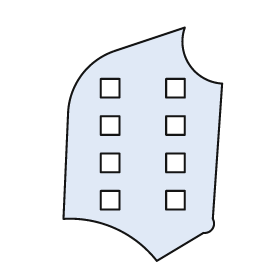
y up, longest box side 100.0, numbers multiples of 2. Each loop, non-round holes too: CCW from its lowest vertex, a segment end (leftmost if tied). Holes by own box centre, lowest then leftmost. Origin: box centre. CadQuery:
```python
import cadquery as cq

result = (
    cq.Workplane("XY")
    .moveTo(6.0, -50.0)
    .lineTo(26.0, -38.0)
    .threePointArc((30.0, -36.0), (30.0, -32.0))
    .lineTo(34.0, 26.0)
    .threePointArc((20.0, 34.0), (18.0, 50.0))
    .lineTo(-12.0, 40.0)
    .threePointArc((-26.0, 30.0), (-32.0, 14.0))
    .lineTo(-34.0, -32.0)
    .threePointArc((-12.0, -36.0), (6.0, -50.0))
    .close()
    .moveTo(-18.0, -28.0)
    .lineTo(-10.0, -28.0)
    .lineTo(-10.0, -20.0)
    .lineTo(-18.0, -20.0)
    .close()
    .moveTo(10.0, -28.0)
    .lineTo(18.0, -28.0)
    .lineTo(18.0, -20.0)
    .lineTo(10.0, -20.0)
    .close()
    .moveTo(-18.0, -12.0)
    .lineTo(-10.0, -12.0)
    .lineTo(-10.0, -4.0)
    .lineTo(-18.0, -4.0)
    .close()
    .moveTo(10.0, -12.0)
    .lineTo(18.0, -12.0)
    .lineTo(18.0, -4.0)
    .lineTo(10.0, -4.0)
    .close()
    .moveTo(-18.0, 4.0)
    .lineTo(-10.0, 4.0)
    .lineTo(-10.0, 12.0)
    .lineTo(-18.0, 12.0)
    .close()
    .moveTo(10.0, 4.0)
    .lineTo(18.0, 4.0)
    .lineTo(18.0, 12.0)
    .lineTo(10.0, 12.0)
    .close()
    .moveTo(-18.0, 20.0)
    .lineTo(-10.0, 20.0)
    .lineTo(-10.0, 28.0)
    .lineTo(-18.0, 28.0)
    .close()
    .moveTo(10.0, 20.0)
    .lineTo(18.0, 20.0)
    .lineTo(18.0, 28.0)
    .lineTo(10.0, 28.0)
    .close()
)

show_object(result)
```